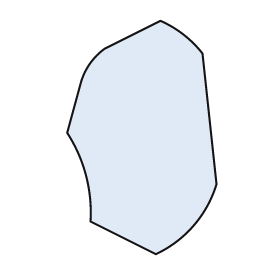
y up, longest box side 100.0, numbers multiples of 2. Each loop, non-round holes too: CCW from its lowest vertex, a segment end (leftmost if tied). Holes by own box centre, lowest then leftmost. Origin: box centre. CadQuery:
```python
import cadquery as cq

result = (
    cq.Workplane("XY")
    .moveTo(6.0, -50.0)
    .threePointArc((22.0, -38.0), (32.0, -20.0))
    .lineTo(26.0, 36.0)
    .threePointArc((18.0, 44.0), (8.0, 50.0))
    .lineTo(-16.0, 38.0)
    .threePointArc((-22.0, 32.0), (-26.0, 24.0))
    .lineTo(-32.0, 2.0)
    .threePointArc((-24.0, -16.0), (-22.0, -36.0))
    .close()
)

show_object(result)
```